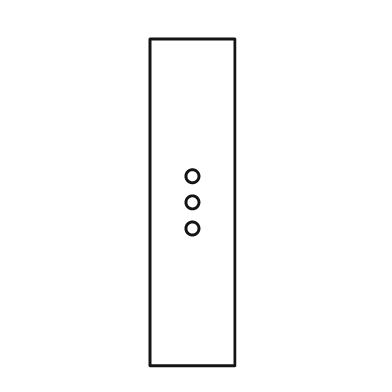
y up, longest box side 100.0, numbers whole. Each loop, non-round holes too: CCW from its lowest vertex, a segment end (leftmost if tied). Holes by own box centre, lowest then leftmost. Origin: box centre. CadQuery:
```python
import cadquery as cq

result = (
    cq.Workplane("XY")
    .moveTo(-13.0, -50.0)
    .lineTo(13.0, -50.0)
    .lineTo(13.0, 50.0)
    .lineTo(-13.0, 50.0)
    .close()
    .moveTo(0.0, -8.0)
    .circle(2.0)
    .moveTo(0.0, 0.0)
    .circle(2.0)
    .moveTo(0.0, 8.0)
    .circle(2.0)
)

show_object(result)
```